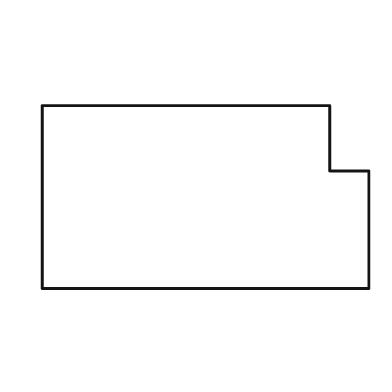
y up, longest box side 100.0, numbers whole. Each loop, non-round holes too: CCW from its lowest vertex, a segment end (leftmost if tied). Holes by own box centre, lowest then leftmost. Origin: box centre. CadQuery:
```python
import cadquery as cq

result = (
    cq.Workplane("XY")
    .moveTo(-50.0, -28.0)
    .lineTo(50.0, -28.0)
    .lineTo(50.0, 8.0)
    .lineTo(38.0, 8.0)
    .lineTo(38.0, 28.0)
    .lineTo(-50.0, 28.0)
    .close()
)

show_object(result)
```